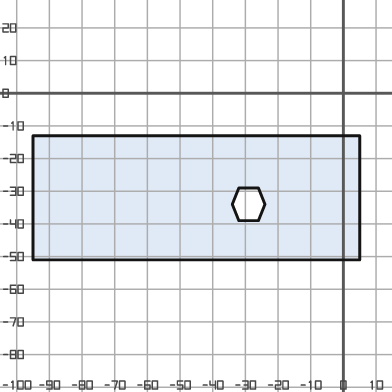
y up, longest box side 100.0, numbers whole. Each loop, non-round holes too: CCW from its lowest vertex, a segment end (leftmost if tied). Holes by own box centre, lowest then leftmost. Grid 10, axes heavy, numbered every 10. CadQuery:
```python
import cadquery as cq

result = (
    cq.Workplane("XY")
    .moveTo(-95.0, -51.0)
    .lineTo(5.0, -51.0)
    .lineTo(5.0, -13.0)
    .lineTo(-95.0, -13.0)
    .close()
    .moveTo(-32.0, -39.0)
    .lineTo(-26.0, -39.0)
    .lineTo(-24.0, -34.0)
    .lineTo(-26.0, -29.0)
    .lineTo(-32.0, -29.0)
    .lineTo(-34.0, -34.0)
    .close()
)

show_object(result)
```